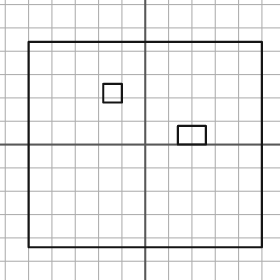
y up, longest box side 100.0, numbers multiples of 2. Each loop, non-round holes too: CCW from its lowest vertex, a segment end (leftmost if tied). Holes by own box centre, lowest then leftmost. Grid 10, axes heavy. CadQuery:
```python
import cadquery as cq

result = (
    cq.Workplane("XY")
    .moveTo(-50.0, -44.0)
    .lineTo(50.0, -44.0)
    .lineTo(50.0, 44.0)
    .lineTo(-50.0, 44.0)
    .close()
    .moveTo(14.0, 0.0)
    .lineTo(26.0, 0.0)
    .lineTo(26.0, 8.0)
    .lineTo(14.0, 8.0)
    .close()
    .moveTo(-18.0, 18.0)
    .lineTo(-10.0, 18.0)
    .lineTo(-10.0, 26.0)
    .lineTo(-18.0, 26.0)
    .close()
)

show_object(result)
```